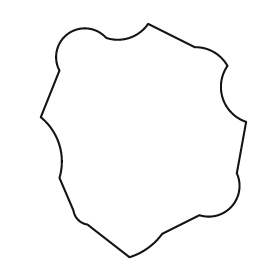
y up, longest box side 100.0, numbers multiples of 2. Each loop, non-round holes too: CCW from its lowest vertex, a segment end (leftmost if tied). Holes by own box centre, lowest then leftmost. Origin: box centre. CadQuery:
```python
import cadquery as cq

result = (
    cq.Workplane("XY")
    .moveTo(-6.0, -50.0)
    .threePointArc((2.0, -46.0), (8.0, -40.0))
    .lineTo(24.0, -32.0)
    .threePointArc((38.0, -28.0), (40.0, -14.0))
    .lineTo(44.0, 8.0)
    .threePointArc((34.0, 18.0), (36.0, 32.0))
    .threePointArc((30.0, 38.0), (22.0, 40.0))
    .lineTo(2.0, 50.0)
    .threePointArc((-6.0, 44.0), (-16.0, 44.0))
    .threePointArc((-32.0, 46.0), (-36.0, 30.0))
    .lineTo(-44.0, 10.0)
    .threePointArc((-36.0, -2.0), (-36.0, -16.0))
    .lineTo(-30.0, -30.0)
    .threePointArc((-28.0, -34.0), (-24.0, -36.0))
    .close()
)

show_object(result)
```